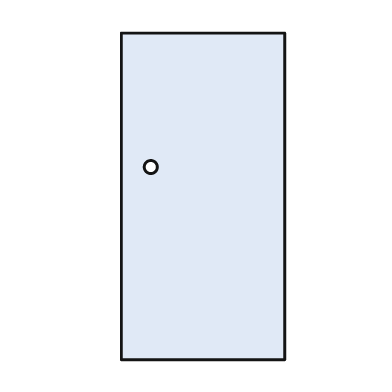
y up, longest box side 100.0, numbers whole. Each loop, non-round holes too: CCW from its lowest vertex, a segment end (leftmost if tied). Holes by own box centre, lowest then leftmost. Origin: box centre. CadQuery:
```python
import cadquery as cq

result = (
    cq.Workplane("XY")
    .moveTo(-25.0, -50.0)
    .lineTo(25.0, -50.0)
    .lineTo(25.0, 50.0)
    .lineTo(-25.0, 50.0)
    .close()
    .moveTo(-16.0, 9.0)
    .circle(2.0)
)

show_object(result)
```